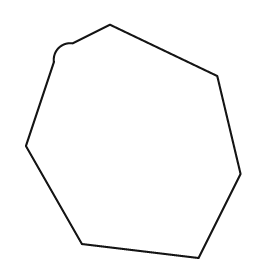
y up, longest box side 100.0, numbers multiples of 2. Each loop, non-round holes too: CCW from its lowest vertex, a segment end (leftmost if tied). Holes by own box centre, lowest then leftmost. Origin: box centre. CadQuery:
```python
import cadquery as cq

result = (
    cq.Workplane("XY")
    .moveTo(28.0, -50.0)
    .lineTo(46.0, -14.0)
    .lineTo(36.0, 28.0)
    .lineTo(-10.0, 50.0)
    .lineTo(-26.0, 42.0)
    .threePointArc((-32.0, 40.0), (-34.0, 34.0))
    .lineTo(-46.0, -2.0)
    .lineTo(-22.0, -44.0)
    .close()
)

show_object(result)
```